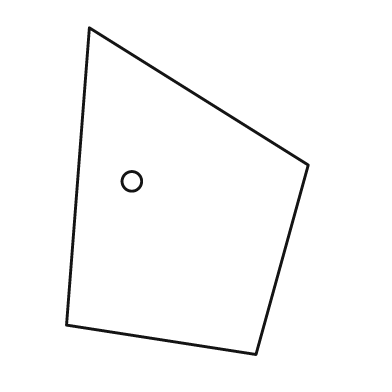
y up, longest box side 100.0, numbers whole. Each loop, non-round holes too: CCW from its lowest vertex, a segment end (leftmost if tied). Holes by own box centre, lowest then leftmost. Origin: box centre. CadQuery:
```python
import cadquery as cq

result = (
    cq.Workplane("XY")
    .moveTo(21.0, -50.0)
    .lineTo(37.0, 8.0)
    .lineTo(-30.0, 50.0)
    .lineTo(-37.0, -41.0)
    .close()
    .moveTo(-17.0, 3.0)
    .circle(3.0)
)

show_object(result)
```